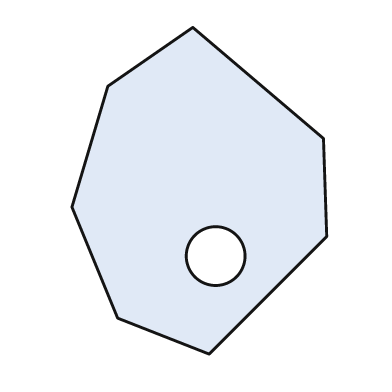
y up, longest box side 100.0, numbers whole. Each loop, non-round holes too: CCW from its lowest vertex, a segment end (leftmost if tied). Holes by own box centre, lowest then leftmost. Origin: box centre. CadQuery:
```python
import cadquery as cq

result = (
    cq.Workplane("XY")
    .moveTo(3.0, -50.0)
    .lineTo(39.0, -14.0)
    .lineTo(38.0, 16.0)
    .lineTo(-2.0, 50.0)
    .lineTo(-28.0, 32.0)
    .lineTo(-39.0, -5.0)
    .lineTo(-25.0, -39.0)
    .close()
    .moveTo(5.0, -20.0)
    .circle(9.0)
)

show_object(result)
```